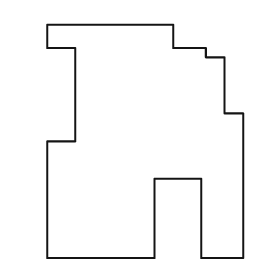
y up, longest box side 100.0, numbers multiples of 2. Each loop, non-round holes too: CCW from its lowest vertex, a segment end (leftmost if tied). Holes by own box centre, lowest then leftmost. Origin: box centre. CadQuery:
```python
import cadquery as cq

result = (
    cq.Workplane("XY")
    .moveTo(-42.0, -50.0)
    .lineTo(4.0, -50.0)
    .lineTo(4.0, -16.0)
    .lineTo(24.0, -16.0)
    .lineTo(24.0, -50.0)
    .lineTo(42.0, -50.0)
    .lineTo(42.0, 12.0)
    .lineTo(34.0, 12.0)
    .lineTo(34.0, 36.0)
    .lineTo(26.0, 36.0)
    .lineTo(26.0, 40.0)
    .lineTo(12.0, 40.0)
    .lineTo(12.0, 50.0)
    .lineTo(-42.0, 50.0)
    .lineTo(-42.0, 40.0)
    .lineTo(-30.0, 40.0)
    .lineTo(-30.0, 0.0)
    .lineTo(-42.0, 0.0)
    .close()
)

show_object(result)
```